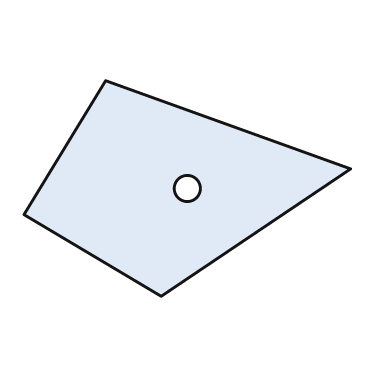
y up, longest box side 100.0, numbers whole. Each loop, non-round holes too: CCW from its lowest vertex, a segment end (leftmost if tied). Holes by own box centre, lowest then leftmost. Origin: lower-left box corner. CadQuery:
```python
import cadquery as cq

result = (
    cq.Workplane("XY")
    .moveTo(42.0, 0.0)
    .lineTo(100.0, 39.0)
    .lineTo(25.0, 66.0)
    .lineTo(0.0, 25.0)
    .close()
    .moveTo(50.0, 33.0)
    .circle(4.0)
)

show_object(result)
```